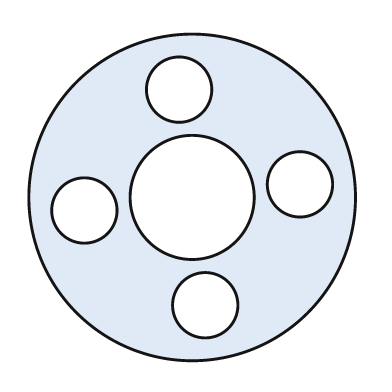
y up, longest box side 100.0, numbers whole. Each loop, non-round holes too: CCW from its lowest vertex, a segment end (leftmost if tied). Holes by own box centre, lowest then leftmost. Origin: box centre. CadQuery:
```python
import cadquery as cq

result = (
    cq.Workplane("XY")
    .moveTo(0.0, 0.0)
    .circle(50.0)
    .moveTo(4.0, -33.0)
    .circle(10.0)
    .moveTo(-33.0, -4.0)
    .circle(10.0)
    .moveTo(0.0, 0.0)
    .circle(19.0)
    .moveTo(33.0, 4.0)
    .circle(10.0)
    .moveTo(-4.0, 33.0)
    .circle(10.0)
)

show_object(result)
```